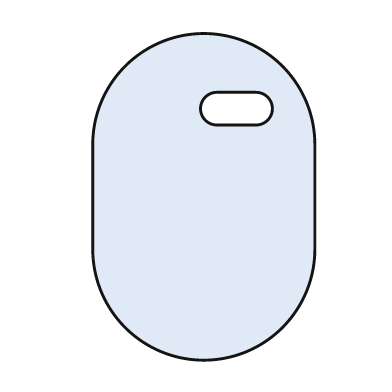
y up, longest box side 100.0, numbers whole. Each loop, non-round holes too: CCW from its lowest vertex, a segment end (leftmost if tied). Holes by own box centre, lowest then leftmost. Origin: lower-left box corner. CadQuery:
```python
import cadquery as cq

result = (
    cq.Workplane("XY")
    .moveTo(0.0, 34.0)
    .threePointArc((34.0, 0.0), (68.0, 34.0))
    .lineTo(68.0, 66.0)
    .threePointArc((34.0, 100.0), (0.0, 66.0))
    .close()
    .moveTo(38.0, 72.0)
    .lineTo(50.0, 72.0)
    .threePointArc((55.0, 77.0), (50.0, 82.0))
    .lineTo(38.0, 82.0)
    .threePointArc((33.0, 77.0), (38.0, 72.0))
    .close()
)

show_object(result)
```